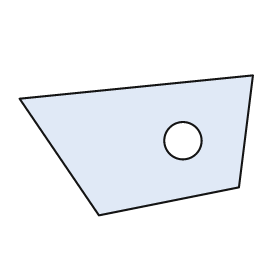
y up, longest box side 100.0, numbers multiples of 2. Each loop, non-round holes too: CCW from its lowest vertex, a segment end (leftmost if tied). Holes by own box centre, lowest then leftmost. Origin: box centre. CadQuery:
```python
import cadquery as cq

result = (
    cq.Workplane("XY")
    .moveTo(-16.0, -30.0)
    .lineTo(44.0, -18.0)
    .lineTo(50.0, 30.0)
    .lineTo(-50.0, 20.0)
    .close()
    .moveTo(20.0, 2.0)
    .circle(8.0)
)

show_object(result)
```